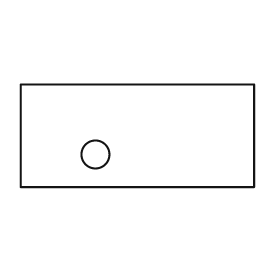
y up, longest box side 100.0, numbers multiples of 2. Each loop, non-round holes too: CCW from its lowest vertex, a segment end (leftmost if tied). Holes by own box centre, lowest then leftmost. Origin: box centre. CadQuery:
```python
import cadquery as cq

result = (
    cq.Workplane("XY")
    .moveTo(-50.0, -22.0)
    .lineTo(50.0, -22.0)
    .lineTo(50.0, 22.0)
    .lineTo(-50.0, 22.0)
    .close()
    .moveTo(-18.0, -8.0)
    .circle(6.0)
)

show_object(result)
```